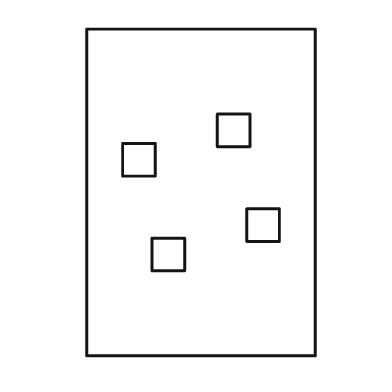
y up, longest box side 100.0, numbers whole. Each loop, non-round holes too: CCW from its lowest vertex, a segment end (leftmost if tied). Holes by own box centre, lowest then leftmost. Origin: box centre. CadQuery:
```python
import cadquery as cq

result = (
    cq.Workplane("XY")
    .moveTo(-35.0, -50.0)
    .lineTo(35.0, -50.0)
    .lineTo(35.0, 50.0)
    .lineTo(-35.0, 50.0)
    .close()
    .moveTo(-15.0, -24.0)
    .lineTo(-5.0, -24.0)
    .lineTo(-5.0, -14.0)
    .lineTo(-15.0, -14.0)
    .close()
    .moveTo(14.0, -15.0)
    .lineTo(24.0, -15.0)
    .lineTo(24.0, -5.0)
    .lineTo(14.0, -5.0)
    .close()
    .moveTo(-24.0, 5.0)
    .lineTo(-14.0, 5.0)
    .lineTo(-14.0, 15.0)
    .lineTo(-24.0, 15.0)
    .close()
    .moveTo(5.0, 14.0)
    .lineTo(15.0, 14.0)
    .lineTo(15.0, 24.0)
    .lineTo(5.0, 24.0)
    .close()
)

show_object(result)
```